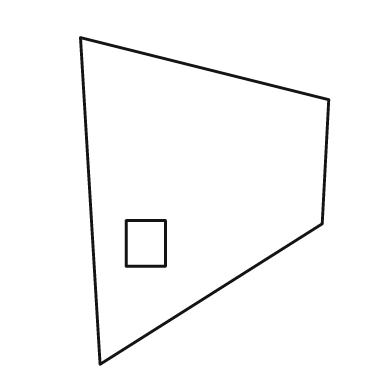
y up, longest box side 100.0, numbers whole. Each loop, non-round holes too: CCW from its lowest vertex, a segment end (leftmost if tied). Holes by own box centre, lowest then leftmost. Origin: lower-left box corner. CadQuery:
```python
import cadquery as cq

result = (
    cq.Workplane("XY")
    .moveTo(6.0, 0.0)
    .lineTo(74.0, 43.0)
    .lineTo(76.0, 81.0)
    .lineTo(0.0, 100.0)
    .close()
    .moveTo(14.0, 30.0)
    .lineTo(26.0, 30.0)
    .lineTo(26.0, 44.0)
    .lineTo(14.0, 44.0)
    .close()
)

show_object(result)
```